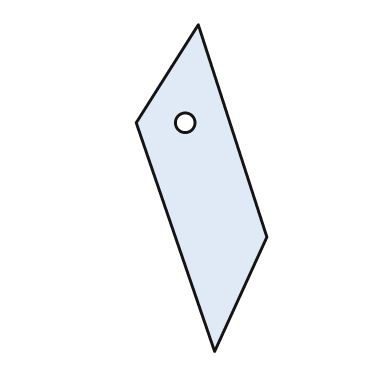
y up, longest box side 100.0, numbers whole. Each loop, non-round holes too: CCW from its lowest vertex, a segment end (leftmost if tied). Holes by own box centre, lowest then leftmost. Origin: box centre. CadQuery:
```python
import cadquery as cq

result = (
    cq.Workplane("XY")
    .moveTo(4.0, -50.0)
    .lineTo(20.0, -15.0)
    .lineTo(-1.0, 50.0)
    .lineTo(-20.0, 20.0)
    .close()
    .moveTo(-5.0, 20.0)
    .circle(3.0)
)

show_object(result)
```